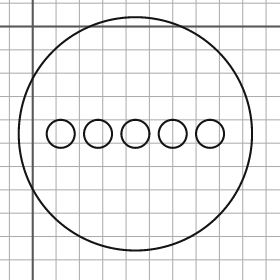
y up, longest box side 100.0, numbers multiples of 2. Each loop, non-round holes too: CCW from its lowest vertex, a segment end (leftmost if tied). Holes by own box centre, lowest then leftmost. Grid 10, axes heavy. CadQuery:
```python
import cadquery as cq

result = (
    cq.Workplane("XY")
    .moveTo(44.0, -46.0)
    .circle(50.0)
    .moveTo(12.0, -46.0)
    .circle(6.0)
    .moveTo(28.0, -46.0)
    .circle(6.0)
    .moveTo(44.0, -46.0)
    .circle(6.0)
    .moveTo(60.0, -46.0)
    .circle(6.0)
    .moveTo(76.0, -46.0)
    .circle(6.0)
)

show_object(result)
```